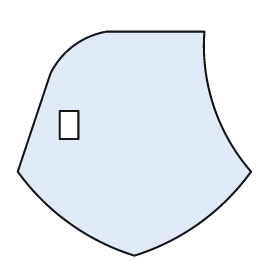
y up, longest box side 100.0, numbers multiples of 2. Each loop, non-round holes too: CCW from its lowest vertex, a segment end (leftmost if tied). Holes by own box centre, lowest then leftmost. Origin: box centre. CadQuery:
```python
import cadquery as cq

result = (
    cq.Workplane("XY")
    .moveTo(0.0, -48.0)
    .threePointArc((28.0, -34.0), (50.0, -12.0))
    .threePointArc((34.0, 16.0), (30.0, 48.0))
    .lineTo(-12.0, 48.0)
    .threePointArc((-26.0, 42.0), (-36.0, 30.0))
    .lineTo(-50.0, -12.0)
    .threePointArc((-28.0, -34.0), (0.0, -48.0))
    .close()
    .moveTo(-32.0, 2.0)
    .lineTo(-24.0, 2.0)
    .lineTo(-24.0, 14.0)
    .lineTo(-32.0, 14.0)
    .close()
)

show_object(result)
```